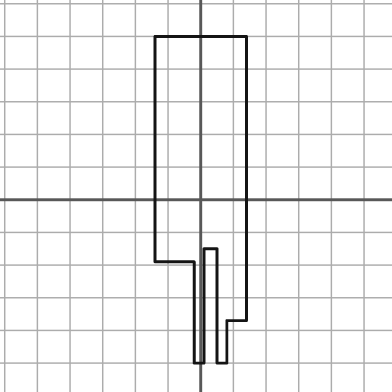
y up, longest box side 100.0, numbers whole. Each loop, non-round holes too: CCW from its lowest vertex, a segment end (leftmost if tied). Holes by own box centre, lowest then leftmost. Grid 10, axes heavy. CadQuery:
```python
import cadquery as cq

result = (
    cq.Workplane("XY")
    .moveTo(-2.0, -50.0)
    .lineTo(1.0, -50.0)
    .lineTo(1.0, -15.0)
    .lineTo(5.0, -15.0)
    .lineTo(5.0, -50.0)
    .lineTo(8.0, -50.0)
    .lineTo(8.0, -37.0)
    .lineTo(14.0, -37.0)
    .lineTo(14.0, 50.0)
    .lineTo(-14.0, 50.0)
    .lineTo(-14.0, -19.0)
    .lineTo(-2.0, -19.0)
    .close()
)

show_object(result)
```